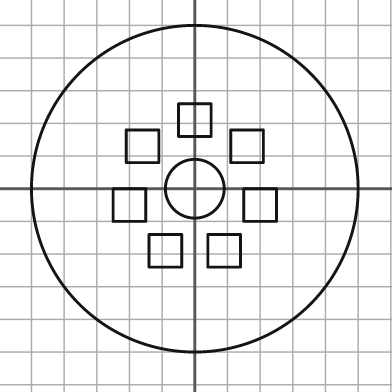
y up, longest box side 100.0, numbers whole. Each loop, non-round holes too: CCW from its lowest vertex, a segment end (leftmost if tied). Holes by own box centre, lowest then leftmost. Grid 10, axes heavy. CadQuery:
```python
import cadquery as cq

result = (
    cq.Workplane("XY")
    .moveTo(0.0, 0.0)
    .circle(50.0)
    .moveTo(-14.0, -24.0)
    .lineTo(-4.0, -24.0)
    .lineTo(-4.0, -14.0)
    .lineTo(-14.0, -14.0)
    .close()
    .moveTo(4.0, -24.0)
    .lineTo(14.0, -24.0)
    .lineTo(14.0, -14.0)
    .lineTo(4.0, -14.0)
    .close()
    .moveTo(-25.0, -10.0)
    .lineTo(-15.0, -10.0)
    .lineTo(-15.0, 0.0)
    .lineTo(-25.0, 0.0)
    .close()
    .moveTo(15.0, -10.0)
    .lineTo(25.0, -10.0)
    .lineTo(25.0, 0.0)
    .lineTo(15.0, 0.0)
    .close()
    .moveTo(0.0, 0.0)
    .circle(9.0)
    .moveTo(-21.0, 8.0)
    .lineTo(-11.0, 8.0)
    .lineTo(-11.0, 18.0)
    .lineTo(-21.0, 18.0)
    .close()
    .moveTo(11.0, 8.0)
    .lineTo(21.0, 8.0)
    .lineTo(21.0, 18.0)
    .lineTo(11.0, 18.0)
    .close()
    .moveTo(-5.0, 16.0)
    .lineTo(5.0, 16.0)
    .lineTo(5.0, 26.0)
    .lineTo(-5.0, 26.0)
    .close()
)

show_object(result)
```